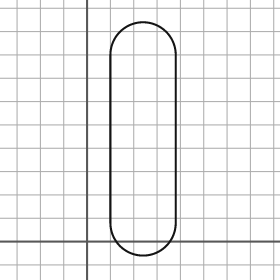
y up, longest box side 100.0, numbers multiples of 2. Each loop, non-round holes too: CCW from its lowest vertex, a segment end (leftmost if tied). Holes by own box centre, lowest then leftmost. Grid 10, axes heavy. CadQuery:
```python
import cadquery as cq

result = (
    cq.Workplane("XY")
    .moveTo(10.0, 8.0)
    .threePointArc((24.0, -6.0), (38.0, 8.0))
    .lineTo(38.0, 80.0)
    .threePointArc((24.0, 94.0), (10.0, 80.0))
    .close()
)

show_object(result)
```